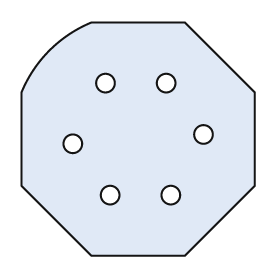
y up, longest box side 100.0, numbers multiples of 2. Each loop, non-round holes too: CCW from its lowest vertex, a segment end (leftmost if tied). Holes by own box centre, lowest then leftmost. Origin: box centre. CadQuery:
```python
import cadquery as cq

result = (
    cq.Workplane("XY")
    .moveTo(-20.0, -50.0)
    .lineTo(20.0, -50.0)
    .lineTo(50.0, -20.0)
    .lineTo(50.0, 20.0)
    .lineTo(20.0, 50.0)
    .lineTo(-20.0, 50.0)
    .threePointArc((-38.0, 38.0), (-50.0, 20.0))
    .lineTo(-50.0, -20.0)
    .close()
    .moveTo(-12.0, -24.0)
    .circle(4.0)
    .moveTo(14.0, -24.0)
    .circle(4.0)
    .moveTo(-28.0, -2.0)
    .circle(4.0)
    .moveTo(28.0, 2.0)
    .circle(4.0)
    .moveTo(-14.0, 24.0)
    .circle(4.0)
    .moveTo(12.0, 24.0)
    .circle(4.0)
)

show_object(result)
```